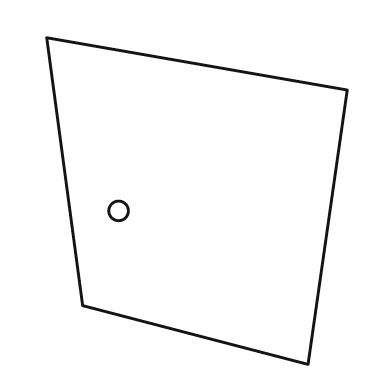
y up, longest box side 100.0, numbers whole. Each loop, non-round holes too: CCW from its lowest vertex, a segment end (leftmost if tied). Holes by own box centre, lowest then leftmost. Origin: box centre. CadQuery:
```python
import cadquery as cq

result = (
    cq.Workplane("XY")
    .moveTo(34.0, -50.0)
    .lineTo(46.0, 34.0)
    .lineTo(-46.0, 50.0)
    .lineTo(-35.0, -32.0)
    .close()
    .moveTo(-24.0, -3.0)
    .circle(3.0)
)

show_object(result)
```